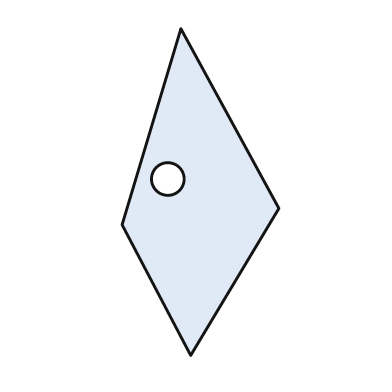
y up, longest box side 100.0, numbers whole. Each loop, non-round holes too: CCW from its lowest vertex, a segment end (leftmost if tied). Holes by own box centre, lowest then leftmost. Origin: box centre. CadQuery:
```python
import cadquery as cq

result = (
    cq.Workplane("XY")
    .moveTo(-3.0, -50.0)
    .lineTo(24.0, -5.0)
    .lineTo(-6.0, 50.0)
    .lineTo(-24.0, -10.0)
    .close()
    .moveTo(-10.0, 4.0)
    .circle(5.0)
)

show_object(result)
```